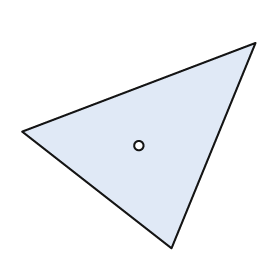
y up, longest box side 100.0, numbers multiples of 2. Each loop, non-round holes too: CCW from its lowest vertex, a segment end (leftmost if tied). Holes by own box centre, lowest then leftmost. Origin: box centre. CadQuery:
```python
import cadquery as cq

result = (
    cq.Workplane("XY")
    .moveTo(14.0, -44.0)
    .lineTo(50.0, 44.0)
    .lineTo(-50.0, 6.0)
    .close()
    .moveTo(0.0, 0.0)
    .circle(2.0)
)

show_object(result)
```